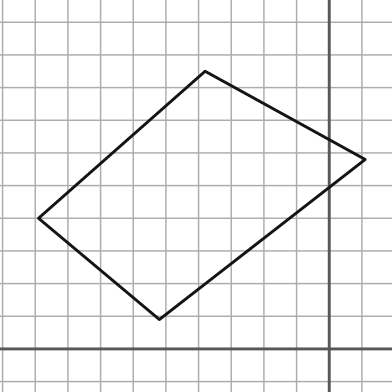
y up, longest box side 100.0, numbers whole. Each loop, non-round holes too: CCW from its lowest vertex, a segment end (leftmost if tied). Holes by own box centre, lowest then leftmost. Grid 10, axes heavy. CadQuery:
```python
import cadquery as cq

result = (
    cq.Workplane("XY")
    .moveTo(-52.0, 9.0)
    .lineTo(11.0, 58.0)
    .lineTo(-38.0, 85.0)
    .lineTo(-89.0, 40.0)
    .close()
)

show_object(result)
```